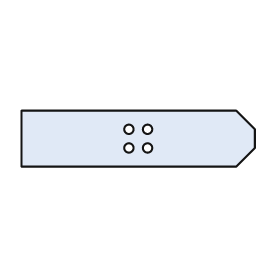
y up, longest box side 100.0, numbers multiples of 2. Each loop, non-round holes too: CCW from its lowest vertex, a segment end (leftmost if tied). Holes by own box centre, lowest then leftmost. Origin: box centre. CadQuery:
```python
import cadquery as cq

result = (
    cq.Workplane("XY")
    .moveTo(-50.0, -12.0)
    .lineTo(42.0, -12.0)
    .lineTo(50.0, -4.0)
    .lineTo(50.0, 4.0)
    .lineTo(42.0, 12.0)
    .lineTo(-50.0, 12.0)
    .close()
    .moveTo(-4.0, -4.0)
    .circle(2.0)
    .moveTo(4.0, -4.0)
    .circle(2.0)
    .moveTo(-4.0, 4.0)
    .circle(2.0)
    .moveTo(4.0, 4.0)
    .circle(2.0)
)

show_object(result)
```